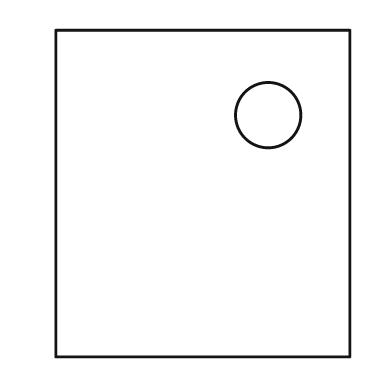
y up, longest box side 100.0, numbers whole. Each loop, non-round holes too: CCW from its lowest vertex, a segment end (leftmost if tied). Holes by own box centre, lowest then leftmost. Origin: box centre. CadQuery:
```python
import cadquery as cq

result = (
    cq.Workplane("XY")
    .moveTo(-45.0, -50.0)
    .lineTo(45.0, -50.0)
    .lineTo(45.0, 50.0)
    .lineTo(-45.0, 50.0)
    .close()
    .moveTo(20.0, 24.0)
    .circle(10.0)
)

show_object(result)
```